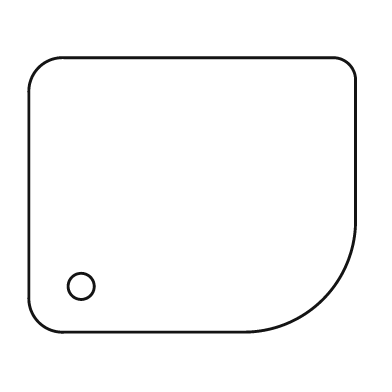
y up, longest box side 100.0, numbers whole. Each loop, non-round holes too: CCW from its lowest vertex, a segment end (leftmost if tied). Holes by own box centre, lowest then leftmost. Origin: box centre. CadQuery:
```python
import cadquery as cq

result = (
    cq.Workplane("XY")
    .moveTo(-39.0, -42.0)
    .lineTo(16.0, -42.0)
    .threePointArc((40.0, -32.0), (50.0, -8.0))
    .lineTo(50.0, 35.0)
    .threePointArc((48.0, 40.0), (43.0, 42.0))
    .lineTo(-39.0, 42.0)
    .threePointArc((-47.0, 39.0), (-50.0, 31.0))
    .lineTo(-50.0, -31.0)
    .threePointArc((-47.0, -39.0), (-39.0, -42.0))
    .close()
    .moveTo(-34.0, -28.0)
    .circle(4.0)
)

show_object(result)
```